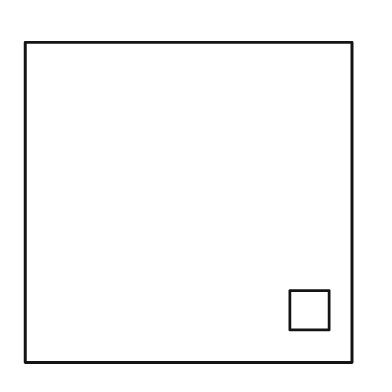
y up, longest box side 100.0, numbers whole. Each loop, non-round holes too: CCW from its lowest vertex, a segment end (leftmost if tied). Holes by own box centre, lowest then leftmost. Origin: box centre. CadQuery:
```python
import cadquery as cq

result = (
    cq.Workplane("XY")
    .moveTo(-50.0, -49.0)
    .lineTo(50.0, -49.0)
    .lineTo(50.0, 49.0)
    .lineTo(-50.0, 49.0)
    .close()
    .moveTo(31.0, -39.0)
    .lineTo(43.0, -39.0)
    .lineTo(43.0, -27.0)
    .lineTo(31.0, -27.0)
    .close()
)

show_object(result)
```